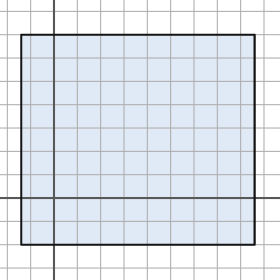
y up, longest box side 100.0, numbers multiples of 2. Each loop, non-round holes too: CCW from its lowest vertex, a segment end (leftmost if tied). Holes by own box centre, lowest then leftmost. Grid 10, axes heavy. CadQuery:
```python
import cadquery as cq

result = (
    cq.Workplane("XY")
    .moveTo(-14.0, -20.0)
    .lineTo(86.0, -20.0)
    .lineTo(86.0, 70.0)
    .lineTo(-14.0, 70.0)
    .close()
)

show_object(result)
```